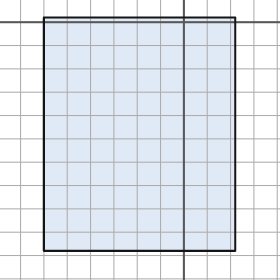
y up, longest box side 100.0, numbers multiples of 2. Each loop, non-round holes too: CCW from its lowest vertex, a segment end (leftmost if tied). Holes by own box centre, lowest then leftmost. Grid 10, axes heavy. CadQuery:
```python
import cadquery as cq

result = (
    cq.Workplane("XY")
    .moveTo(-60.0, -98.0)
    .lineTo(22.0, -98.0)
    .lineTo(22.0, 2.0)
    .lineTo(-60.0, 2.0)
    .close()
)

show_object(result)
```